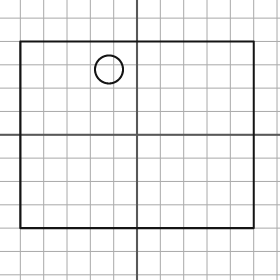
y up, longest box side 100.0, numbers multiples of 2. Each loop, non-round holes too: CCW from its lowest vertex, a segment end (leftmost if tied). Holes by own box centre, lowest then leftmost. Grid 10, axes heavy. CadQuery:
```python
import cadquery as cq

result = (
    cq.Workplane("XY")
    .moveTo(-50.0, -40.0)
    .lineTo(50.0, -40.0)
    .lineTo(50.0, 40.0)
    .lineTo(-50.0, 40.0)
    .close()
    .moveTo(-12.0, 28.0)
    .circle(6.0)
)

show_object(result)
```